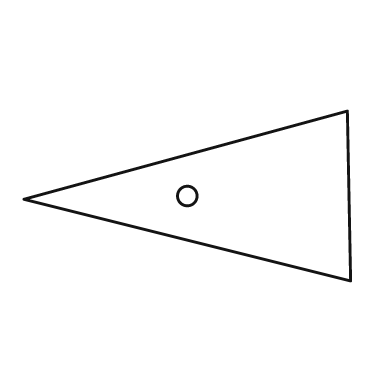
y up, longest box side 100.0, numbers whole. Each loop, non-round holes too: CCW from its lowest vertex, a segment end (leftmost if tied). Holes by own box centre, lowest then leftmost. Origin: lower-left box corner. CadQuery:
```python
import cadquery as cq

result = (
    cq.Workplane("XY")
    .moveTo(100.0, 0.0)
    .lineTo(99.0, 52.0)
    .lineTo(0.0, 25.0)
    .close()
    .moveTo(50.0, 26.0)
    .circle(3.0)
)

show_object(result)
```